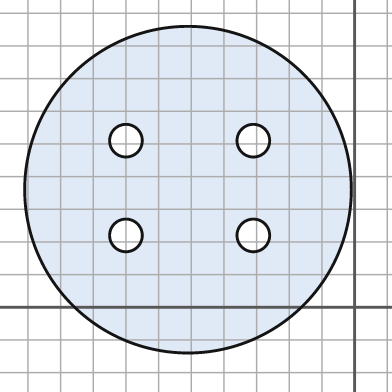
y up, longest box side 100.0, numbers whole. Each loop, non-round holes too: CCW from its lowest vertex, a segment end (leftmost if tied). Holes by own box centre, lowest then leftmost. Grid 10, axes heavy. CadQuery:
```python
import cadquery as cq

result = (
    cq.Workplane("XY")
    .moveTo(-51.0, 36.0)
    .circle(50.0)
    .moveTo(-70.0, 22.0)
    .circle(5.0)
    .moveTo(-31.0, 22.0)
    .circle(5.0)
    .moveTo(-70.0, 51.0)
    .circle(5.0)
    .moveTo(-31.0, 51.0)
    .circle(5.0)
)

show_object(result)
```